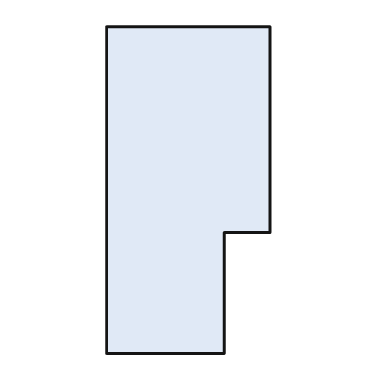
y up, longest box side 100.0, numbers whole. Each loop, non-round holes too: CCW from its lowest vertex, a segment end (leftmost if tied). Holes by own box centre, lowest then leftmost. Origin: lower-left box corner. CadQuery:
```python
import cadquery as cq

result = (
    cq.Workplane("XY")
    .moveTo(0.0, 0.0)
    .lineTo(36.0, 0.0)
    .lineTo(36.0, 37.0)
    .lineTo(50.0, 37.0)
    .lineTo(50.0, 100.0)
    .lineTo(0.0, 100.0)
    .close()
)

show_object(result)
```